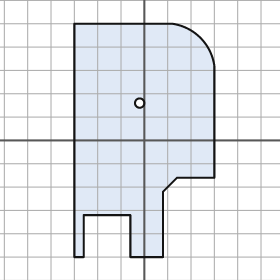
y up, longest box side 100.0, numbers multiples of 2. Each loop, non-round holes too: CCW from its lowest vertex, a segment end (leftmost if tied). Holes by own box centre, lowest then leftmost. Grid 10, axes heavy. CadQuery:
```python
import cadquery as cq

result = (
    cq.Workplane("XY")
    .moveTo(-30.0, -50.0)
    .lineTo(-26.0, -50.0)
    .lineTo(-26.0, -32.0)
    .lineTo(-6.0, -32.0)
    .lineTo(-6.0, -50.0)
    .lineTo(8.0, -50.0)
    .lineTo(8.0, -22.0)
    .lineTo(14.0, -16.0)
    .lineTo(30.0, -16.0)
    .lineTo(30.0, 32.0)
    .threePointArc((24.0, 44.0), (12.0, 50.0))
    .lineTo(-30.0, 50.0)
    .close()
    .moveTo(-2.0, 16.0)
    .circle(2.0)
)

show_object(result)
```